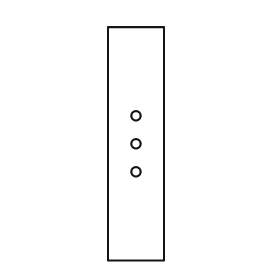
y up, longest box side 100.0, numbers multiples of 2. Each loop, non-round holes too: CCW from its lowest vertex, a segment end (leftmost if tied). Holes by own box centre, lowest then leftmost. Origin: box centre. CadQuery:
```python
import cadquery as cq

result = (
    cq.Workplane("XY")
    .moveTo(-12.0, -50.0)
    .lineTo(12.0, -50.0)
    .lineTo(12.0, 50.0)
    .lineTo(-12.0, 50.0)
    .close()
    .moveTo(0.0, -12.0)
    .circle(2.0)
    .moveTo(0.0, 0.0)
    .circle(2.0)
    .moveTo(0.0, 12.0)
    .circle(2.0)
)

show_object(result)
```